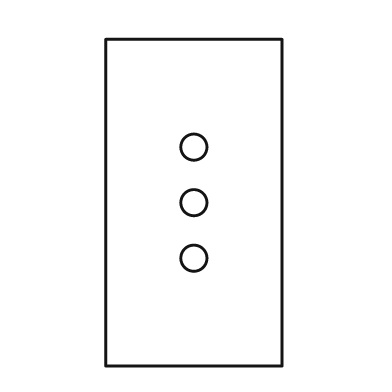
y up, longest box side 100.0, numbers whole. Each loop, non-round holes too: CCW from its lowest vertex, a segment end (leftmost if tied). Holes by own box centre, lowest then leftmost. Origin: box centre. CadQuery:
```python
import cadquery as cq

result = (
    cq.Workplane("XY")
    .moveTo(-27.0, -50.0)
    .lineTo(27.0, -50.0)
    .lineTo(27.0, 50.0)
    .lineTo(-27.0, 50.0)
    .close()
    .moveTo(0.0, -17.0)
    .circle(4.0)
    .moveTo(0.0, 0.0)
    .circle(4.0)
    .moveTo(0.0, 17.0)
    .circle(4.0)
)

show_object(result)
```